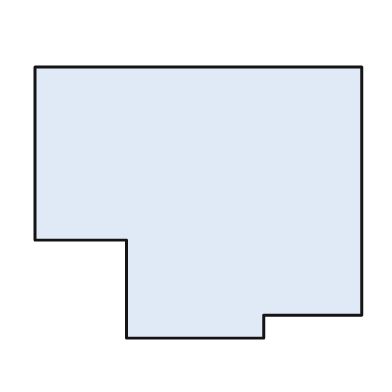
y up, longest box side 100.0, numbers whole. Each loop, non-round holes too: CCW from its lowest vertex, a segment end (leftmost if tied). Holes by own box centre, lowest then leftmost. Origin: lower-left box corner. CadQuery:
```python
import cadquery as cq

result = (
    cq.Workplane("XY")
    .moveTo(28.0, 0.0)
    .lineTo(70.0, 0.0)
    .lineTo(70.0, 7.0)
    .lineTo(100.0, 7.0)
    .lineTo(100.0, 83.0)
    .lineTo(0.0, 83.0)
    .lineTo(0.0, 30.0)
    .lineTo(28.0, 30.0)
    .close()
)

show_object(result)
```